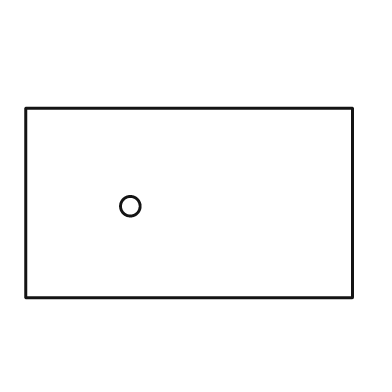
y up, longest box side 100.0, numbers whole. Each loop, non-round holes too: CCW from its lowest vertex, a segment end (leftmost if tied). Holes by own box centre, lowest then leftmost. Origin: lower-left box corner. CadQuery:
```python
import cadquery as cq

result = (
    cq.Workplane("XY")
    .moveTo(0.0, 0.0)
    .lineTo(100.0, 0.0)
    .lineTo(100.0, 58.0)
    .lineTo(0.0, 58.0)
    .close()
    .moveTo(32.0, 28.0)
    .circle(3.0)
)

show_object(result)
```